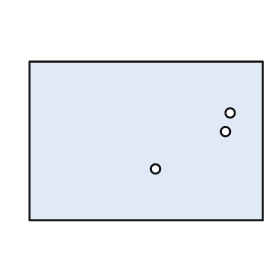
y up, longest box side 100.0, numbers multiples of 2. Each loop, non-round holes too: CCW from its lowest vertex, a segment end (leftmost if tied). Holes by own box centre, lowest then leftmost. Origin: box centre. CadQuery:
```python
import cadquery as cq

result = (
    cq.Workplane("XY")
    .moveTo(-50.0, -34.0)
    .lineTo(50.0, -34.0)
    .lineTo(50.0, 34.0)
    .lineTo(-50.0, 34.0)
    .close()
    .moveTo(4.0, -12.0)
    .circle(2.0)
    .moveTo(34.0, 4.0)
    .circle(2.0)
    .moveTo(36.0, 12.0)
    .circle(2.0)
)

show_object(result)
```